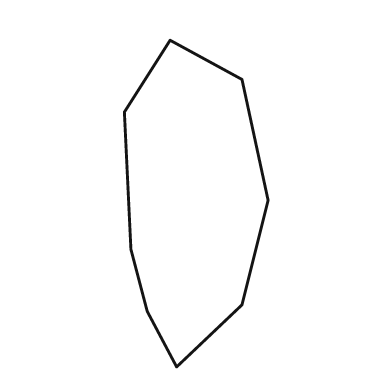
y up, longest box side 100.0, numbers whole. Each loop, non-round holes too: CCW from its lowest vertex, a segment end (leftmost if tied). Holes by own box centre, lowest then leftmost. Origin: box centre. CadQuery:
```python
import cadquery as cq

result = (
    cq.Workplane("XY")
    .moveTo(-6.0, -50.0)
    .lineTo(14.0, -31.0)
    .lineTo(22.0, 1.0)
    .lineTo(14.0, 38.0)
    .lineTo(-8.0, 50.0)
    .lineTo(-22.0, 28.0)
    .lineTo(-20.0, -14.0)
    .lineTo(-15.0, -33.0)
    .close()
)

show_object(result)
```